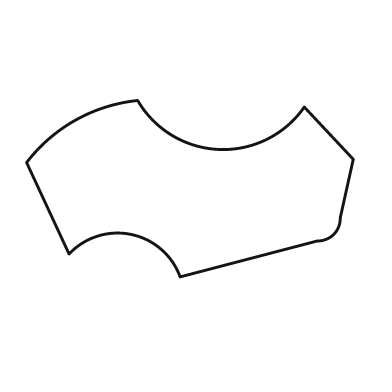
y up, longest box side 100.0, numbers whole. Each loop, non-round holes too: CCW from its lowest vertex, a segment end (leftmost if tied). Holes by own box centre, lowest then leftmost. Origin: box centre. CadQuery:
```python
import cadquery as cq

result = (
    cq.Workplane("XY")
    .moveTo(-3.0, -27.0)
    .lineTo(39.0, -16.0)
    .threePointArc((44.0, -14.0), (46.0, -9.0))
    .lineTo(50.0, 9.0)
    .lineTo(35.0, 25.0)
    .threePointArc((9.0, 12.0), (-16.0, 27.0))
    .threePointArc((-35.0, 21.0), (-50.0, 8.0))
    .lineTo(-37.0, -20.0)
    .threePointArc((-18.0, -14.0), (-3.0, -27.0))
    .close()
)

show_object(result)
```